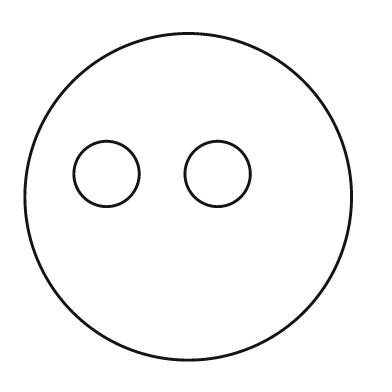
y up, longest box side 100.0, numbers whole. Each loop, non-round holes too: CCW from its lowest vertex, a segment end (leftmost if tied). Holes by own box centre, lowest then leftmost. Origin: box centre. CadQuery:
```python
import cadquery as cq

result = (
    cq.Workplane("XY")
    .moveTo(0.0, 0.0)
    .circle(50.0)
    .moveTo(-25.0, 7.0)
    .circle(10.0)
    .moveTo(9.0, 7.0)
    .circle(10.0)
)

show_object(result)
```